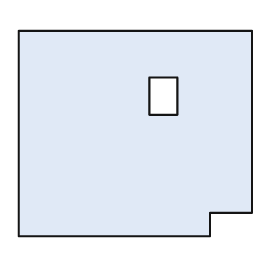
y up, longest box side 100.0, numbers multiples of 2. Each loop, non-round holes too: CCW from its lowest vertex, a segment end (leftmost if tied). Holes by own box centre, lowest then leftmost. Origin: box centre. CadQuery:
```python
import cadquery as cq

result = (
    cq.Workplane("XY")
    .moveTo(-50.0, -44.0)
    .lineTo(32.0, -44.0)
    .lineTo(32.0, -34.0)
    .lineTo(50.0, -34.0)
    .lineTo(50.0, 44.0)
    .lineTo(-50.0, 44.0)
    .close()
    .moveTo(6.0, 8.0)
    .lineTo(18.0, 8.0)
    .lineTo(18.0, 24.0)
    .lineTo(6.0, 24.0)
    .close()
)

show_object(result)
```